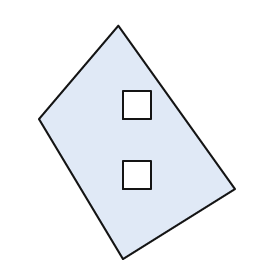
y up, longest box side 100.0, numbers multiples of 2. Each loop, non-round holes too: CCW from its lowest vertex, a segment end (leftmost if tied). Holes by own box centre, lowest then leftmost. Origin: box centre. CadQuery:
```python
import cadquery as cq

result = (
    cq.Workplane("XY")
    .moveTo(-6.0, -50.0)
    .lineTo(42.0, -20.0)
    .lineTo(-8.0, 50.0)
    .lineTo(-42.0, 10.0)
    .close()
    .moveTo(-6.0, -20.0)
    .lineTo(6.0, -20.0)
    .lineTo(6.0, -8.0)
    .lineTo(-6.0, -8.0)
    .close()
    .moveTo(-6.0, 10.0)
    .lineTo(6.0, 10.0)
    .lineTo(6.0, 22.0)
    .lineTo(-6.0, 22.0)
    .close()
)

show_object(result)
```